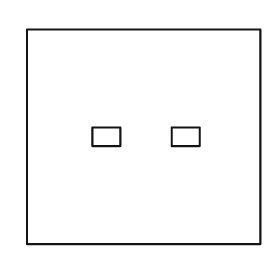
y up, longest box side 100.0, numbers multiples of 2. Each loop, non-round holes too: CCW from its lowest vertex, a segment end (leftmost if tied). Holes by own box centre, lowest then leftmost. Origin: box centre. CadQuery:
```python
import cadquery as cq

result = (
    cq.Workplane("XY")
    .moveTo(-50.0, -46.0)
    .lineTo(50.0, -46.0)
    .lineTo(50.0, 46.0)
    .lineTo(-50.0, 46.0)
    .close()
    .moveTo(-22.0, -4.0)
    .lineTo(-10.0, -4.0)
    .lineTo(-10.0, 4.0)
    .lineTo(-22.0, 4.0)
    .close()
    .moveTo(12.0, -4.0)
    .lineTo(24.0, -4.0)
    .lineTo(24.0, 4.0)
    .lineTo(12.0, 4.0)
    .close()
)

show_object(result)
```